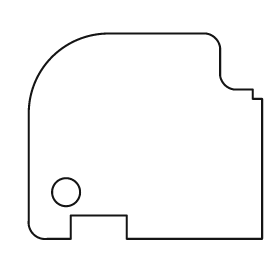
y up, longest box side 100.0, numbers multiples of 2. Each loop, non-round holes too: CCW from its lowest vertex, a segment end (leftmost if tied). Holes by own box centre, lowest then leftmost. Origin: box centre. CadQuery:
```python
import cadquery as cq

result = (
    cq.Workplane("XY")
    .moveTo(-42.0, -44.0)
    .lineTo(-32.0, -44.0)
    .lineTo(-32.0, -34.0)
    .lineTo(-8.0, -34.0)
    .lineTo(-8.0, -44.0)
    .lineTo(50.0, -44.0)
    .lineTo(50.0, 16.0)
    .lineTo(46.0, 16.0)
    .lineTo(46.0, 20.0)
    .lineTo(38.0, 20.0)
    .threePointArc((34.0, 22.0), (32.0, 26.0))
    .lineTo(32.0, 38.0)
    .threePointArc((30.0, 42.0), (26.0, 44.0))
    .lineTo(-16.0, 44.0)
    .threePointArc((-40.0, 34.0), (-50.0, 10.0))
    .lineTo(-50.0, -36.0)
    .threePointArc((-48.0, -42.0), (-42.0, -44.0))
    .close()
    .moveTo(-34.0, -24.0)
    .circle(6.0)
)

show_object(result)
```